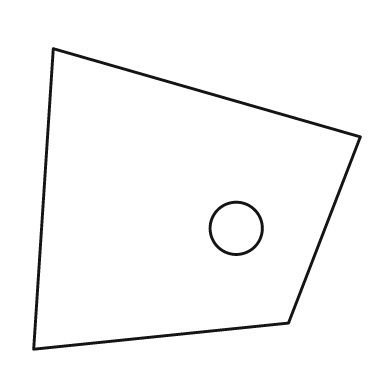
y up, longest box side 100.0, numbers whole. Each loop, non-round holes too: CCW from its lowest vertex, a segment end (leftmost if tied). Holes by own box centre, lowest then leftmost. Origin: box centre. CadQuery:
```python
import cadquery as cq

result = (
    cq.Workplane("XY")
    .moveTo(-50.0, -46.0)
    .lineTo(28.0, -38.0)
    .lineTo(50.0, 19.0)
    .lineTo(-44.0, 46.0)
    .close()
    .moveTo(12.0, -9.0)
    .circle(8.0)
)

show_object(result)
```